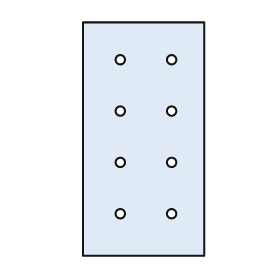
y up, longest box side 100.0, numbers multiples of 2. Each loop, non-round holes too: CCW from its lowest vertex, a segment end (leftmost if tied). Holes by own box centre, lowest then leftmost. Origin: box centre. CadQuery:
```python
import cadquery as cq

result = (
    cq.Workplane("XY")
    .moveTo(-26.0, -50.0)
    .lineTo(26.0, -50.0)
    .lineTo(26.0, 50.0)
    .lineTo(-26.0, 50.0)
    .close()
    .moveTo(-10.0, -32.0)
    .circle(2.0)
    .moveTo(12.0, -32.0)
    .circle(2.0)
    .moveTo(-10.0, -10.0)
    .circle(2.0)
    .moveTo(12.0, -10.0)
    .circle(2.0)
    .moveTo(-10.0, 12.0)
    .circle(2.0)
    .moveTo(12.0, 12.0)
    .circle(2.0)
    .moveTo(-10.0, 34.0)
    .circle(2.0)
    .moveTo(12.0, 34.0)
    .circle(2.0)
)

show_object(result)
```